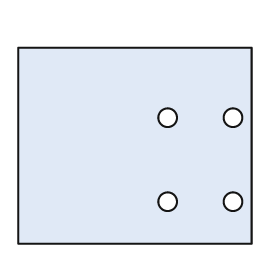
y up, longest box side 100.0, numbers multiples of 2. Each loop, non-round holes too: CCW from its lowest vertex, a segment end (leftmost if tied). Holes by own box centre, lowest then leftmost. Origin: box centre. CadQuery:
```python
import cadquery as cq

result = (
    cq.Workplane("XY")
    .moveTo(-50.0, -42.0)
    .lineTo(50.0, -42.0)
    .lineTo(50.0, 42.0)
    .lineTo(-50.0, 42.0)
    .close()
    .moveTo(14.0, -24.0)
    .circle(4.0)
    .moveTo(42.0, -24.0)
    .circle(4.0)
    .moveTo(14.0, 12.0)
    .circle(4.0)
    .moveTo(42.0, 12.0)
    .circle(4.0)
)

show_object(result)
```